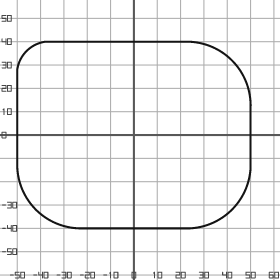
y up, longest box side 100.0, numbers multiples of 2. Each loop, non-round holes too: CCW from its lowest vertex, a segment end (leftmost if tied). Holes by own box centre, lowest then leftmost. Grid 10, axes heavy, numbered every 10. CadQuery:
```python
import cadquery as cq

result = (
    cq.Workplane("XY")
    .moveTo(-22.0, -40.0)
    .lineTo(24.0, -40.0)
    .threePointArc((42.0, -32.0), (50.0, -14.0))
    .lineTo(50.0, 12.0)
    .threePointArc((42.0, 32.0), (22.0, 40.0))
    .lineTo(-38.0, 40.0)
    .threePointArc((-46.0, 36.0), (-50.0, 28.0))
    .lineTo(-50.0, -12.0)
    .threePointArc((-42.0, -32.0), (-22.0, -40.0))
    .close()
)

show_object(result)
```